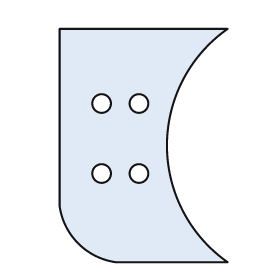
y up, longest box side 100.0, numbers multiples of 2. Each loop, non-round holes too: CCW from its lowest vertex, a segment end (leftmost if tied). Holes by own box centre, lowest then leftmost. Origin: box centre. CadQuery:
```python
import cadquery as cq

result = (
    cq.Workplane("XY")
    .moveTo(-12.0, -50.0)
    .lineTo(36.0, -50.0)
    .threePointArc((10.0, 0.0), (36.0, 50.0))
    .lineTo(-36.0, 50.0)
    .lineTo(-36.0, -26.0)
    .threePointArc((-28.0, -42.0), (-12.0, -50.0))
    .close()
    .moveTo(-18.0, -12.0)
    .circle(4.0)
    .moveTo(-2.0, -12.0)
    .circle(4.0)
    .moveTo(-18.0, 18.0)
    .circle(4.0)
    .moveTo(-2.0, 18.0)
    .circle(4.0)
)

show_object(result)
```